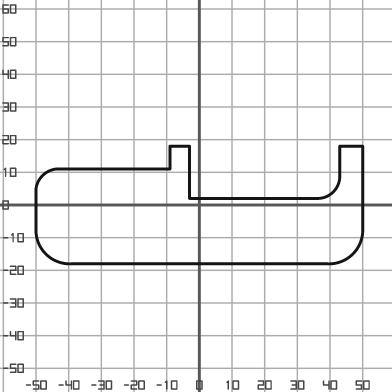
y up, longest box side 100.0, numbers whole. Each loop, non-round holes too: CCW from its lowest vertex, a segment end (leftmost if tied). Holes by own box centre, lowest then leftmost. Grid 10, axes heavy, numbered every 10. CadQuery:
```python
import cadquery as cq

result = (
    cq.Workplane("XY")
    .moveTo(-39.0, -18.0)
    .lineTo(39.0, -18.0)
    .threePointArc((47.0, -15.0), (50.0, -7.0))
    .lineTo(50.0, 18.0)
    .lineTo(43.0, 18.0)
    .lineTo(43.0, 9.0)
    .threePointArc((41.0, 4.0), (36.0, 2.0))
    .lineTo(-3.0, 2.0)
    .lineTo(-3.0, 18.0)
    .lineTo(-9.0, 18.0)
    .lineTo(-9.0, 11.0)
    .lineTo(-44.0, 11.0)
    .threePointArc((-48.0, 9.0), (-50.0, 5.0))
    .lineTo(-50.0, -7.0)
    .threePointArc((-47.0, -15.0), (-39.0, -18.0))
    .close()
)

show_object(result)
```